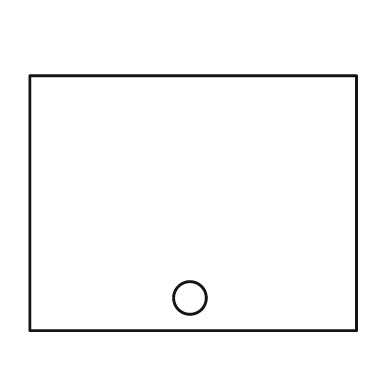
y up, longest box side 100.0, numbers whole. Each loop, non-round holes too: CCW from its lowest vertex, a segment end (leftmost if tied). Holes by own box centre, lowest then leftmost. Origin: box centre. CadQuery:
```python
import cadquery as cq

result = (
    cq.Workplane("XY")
    .moveTo(-50.0, -39.0)
    .lineTo(50.0, -39.0)
    .lineTo(50.0, 39.0)
    .lineTo(-50.0, 39.0)
    .close()
    .moveTo(-1.0, -29.0)
    .circle(5.0)
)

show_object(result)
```